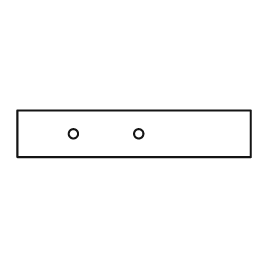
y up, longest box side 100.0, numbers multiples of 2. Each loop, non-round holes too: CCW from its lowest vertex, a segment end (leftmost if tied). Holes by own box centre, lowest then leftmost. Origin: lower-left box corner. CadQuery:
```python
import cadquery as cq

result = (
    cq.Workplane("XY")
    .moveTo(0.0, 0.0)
    .lineTo(100.0, 0.0)
    .lineTo(100.0, 20.0)
    .lineTo(0.0, 20.0)
    .close()
    .moveTo(24.0, 10.0)
    .circle(2.0)
    .moveTo(52.0, 10.0)
    .circle(2.0)
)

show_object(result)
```